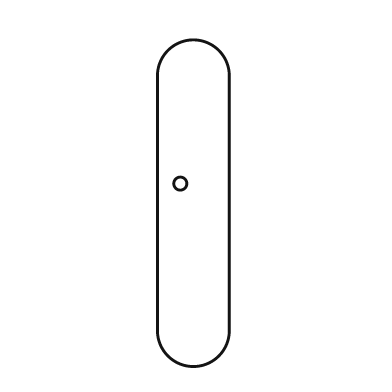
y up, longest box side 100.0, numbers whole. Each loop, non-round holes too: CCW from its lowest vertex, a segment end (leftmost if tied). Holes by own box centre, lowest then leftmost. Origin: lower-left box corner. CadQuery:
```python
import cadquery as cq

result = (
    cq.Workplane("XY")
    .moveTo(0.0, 11.0)
    .threePointArc((11.0, 0.0), (22.0, 11.0))
    .lineTo(22.0, 89.0)
    .threePointArc((11.0, 100.0), (0.0, 89.0))
    .close()
    .moveTo(7.0, 56.0)
    .circle(2.0)
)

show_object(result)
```